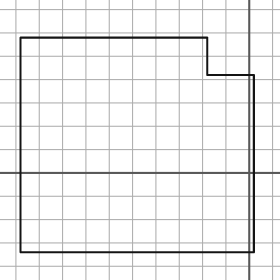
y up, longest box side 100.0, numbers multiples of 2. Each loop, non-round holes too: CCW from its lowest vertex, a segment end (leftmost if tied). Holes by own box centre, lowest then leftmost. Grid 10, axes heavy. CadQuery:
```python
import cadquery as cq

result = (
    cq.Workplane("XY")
    .moveTo(-98.0, -34.0)
    .lineTo(2.0, -34.0)
    .lineTo(2.0, 42.0)
    .lineTo(-18.0, 42.0)
    .lineTo(-18.0, 58.0)
    .lineTo(-98.0, 58.0)
    .close()
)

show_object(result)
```